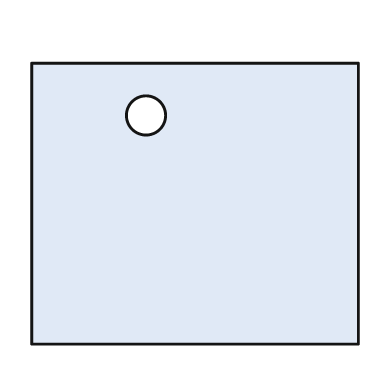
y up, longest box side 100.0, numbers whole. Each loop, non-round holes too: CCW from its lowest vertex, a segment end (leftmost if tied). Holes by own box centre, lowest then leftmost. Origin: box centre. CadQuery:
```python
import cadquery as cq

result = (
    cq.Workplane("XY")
    .moveTo(-50.0, -43.0)
    .lineTo(50.0, -43.0)
    .lineTo(50.0, 43.0)
    .lineTo(-50.0, 43.0)
    .close()
    .moveTo(-15.0, 27.0)
    .circle(6.0)
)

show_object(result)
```